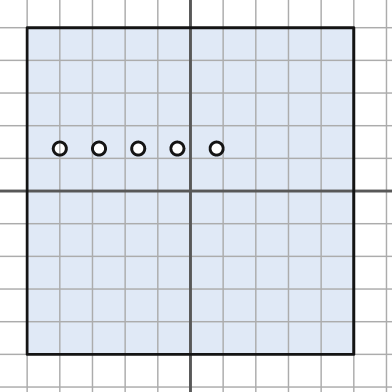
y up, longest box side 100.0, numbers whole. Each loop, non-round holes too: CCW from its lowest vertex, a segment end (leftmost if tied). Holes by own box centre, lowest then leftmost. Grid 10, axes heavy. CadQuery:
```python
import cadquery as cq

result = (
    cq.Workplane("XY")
    .moveTo(-50.0, -50.0)
    .lineTo(50.0, -50.0)
    .lineTo(50.0, 50.0)
    .lineTo(-50.0, 50.0)
    .close()
    .moveTo(-40.0, 13.0)
    .circle(2.0)
    .moveTo(-28.0, 13.0)
    .circle(2.0)
    .moveTo(-16.0, 13.0)
    .circle(2.0)
    .moveTo(-4.0, 13.0)
    .circle(2.0)
    .moveTo(8.0, 13.0)
    .circle(2.0)
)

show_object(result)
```